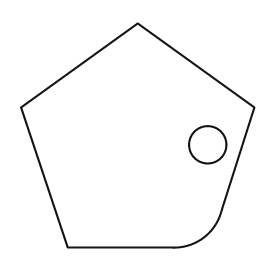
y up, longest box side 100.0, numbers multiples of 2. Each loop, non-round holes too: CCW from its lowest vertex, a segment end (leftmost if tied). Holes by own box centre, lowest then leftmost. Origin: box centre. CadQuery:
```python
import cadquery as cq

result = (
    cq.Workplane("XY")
    .moveTo(-30.0, -48.0)
    .lineTo(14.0, -48.0)
    .threePointArc((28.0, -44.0), (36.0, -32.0))
    .lineTo(50.0, 12.0)
    .lineTo(0.0, 48.0)
    .lineTo(-50.0, 12.0)
    .close()
    .moveTo(30.0, -4.0)
    .circle(8.0)
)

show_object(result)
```